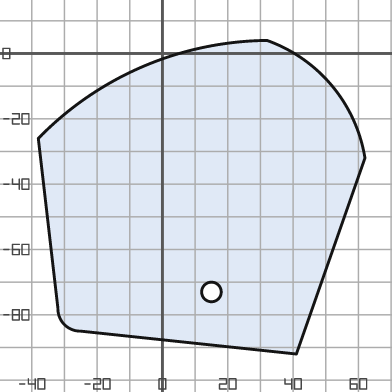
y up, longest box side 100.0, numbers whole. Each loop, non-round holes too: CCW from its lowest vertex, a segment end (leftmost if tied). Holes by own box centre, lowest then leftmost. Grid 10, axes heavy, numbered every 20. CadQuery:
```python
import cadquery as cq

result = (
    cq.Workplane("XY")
    .moveTo(41.0, -92.0)
    .lineTo(62.0, -32.0)
    .threePointArc((52.0, -10.0), (32.0, 4.0))
    .threePointArc((-6.0, -4.0), (-38.0, -26.0))
    .lineTo(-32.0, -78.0)
    .threePointArc((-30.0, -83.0), (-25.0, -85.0))
    .close()
    .moveTo(15.0, -73.0)
    .circle(3.0)
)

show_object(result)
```